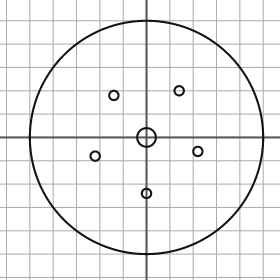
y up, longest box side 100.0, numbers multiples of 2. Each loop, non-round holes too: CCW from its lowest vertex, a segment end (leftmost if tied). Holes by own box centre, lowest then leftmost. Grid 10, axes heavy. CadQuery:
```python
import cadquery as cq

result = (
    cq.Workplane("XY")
    .moveTo(0.0, 0.0)
    .circle(50.0)
    .moveTo(0.0, -24.0)
    .circle(2.0)
    .moveTo(-22.0, -8.0)
    .circle(2.0)
    .moveTo(22.0, -6.0)
    .circle(2.0)
    .moveTo(0.0, 0.0)
    .circle(4.0)
    .moveTo(-14.0, 18.0)
    .circle(2.0)
    .moveTo(14.0, 20.0)
    .circle(2.0)
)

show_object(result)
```